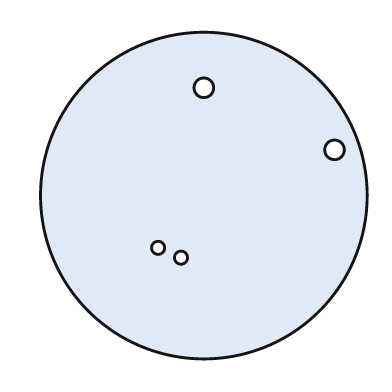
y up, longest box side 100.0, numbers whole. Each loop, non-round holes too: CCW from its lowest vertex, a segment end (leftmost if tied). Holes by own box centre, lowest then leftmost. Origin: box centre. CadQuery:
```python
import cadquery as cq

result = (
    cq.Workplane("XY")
    .moveTo(0.0, 0.0)
    .circle(50.0)
    .moveTo(-7.0, -19.0)
    .circle(2.0)
    .moveTo(-14.0, -16.0)
    .circle(2.0)
    .moveTo(40.0, 14.0)
    .circle(3.0)
    .moveTo(0.0, 33.0)
    .circle(3.0)
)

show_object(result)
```